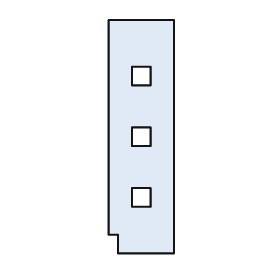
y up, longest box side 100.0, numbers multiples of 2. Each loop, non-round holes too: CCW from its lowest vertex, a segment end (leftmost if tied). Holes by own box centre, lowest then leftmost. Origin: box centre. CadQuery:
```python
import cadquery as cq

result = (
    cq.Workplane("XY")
    .moveTo(-10.0, -50.0)
    .lineTo(14.0, -50.0)
    .lineTo(14.0, 50.0)
    .lineTo(-14.0, 50.0)
    .lineTo(-14.0, -42.0)
    .lineTo(-10.0, -42.0)
    .close()
    .moveTo(-4.0, -30.0)
    .lineTo(4.0, -30.0)
    .lineTo(4.0, -22.0)
    .lineTo(-4.0, -22.0)
    .close()
    .moveTo(-4.0, -4.0)
    .lineTo(4.0, -4.0)
    .lineTo(4.0, 4.0)
    .lineTo(-4.0, 4.0)
    .close()
    .moveTo(-4.0, 22.0)
    .lineTo(4.0, 22.0)
    .lineTo(4.0, 30.0)
    .lineTo(-4.0, 30.0)
    .close()
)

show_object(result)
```